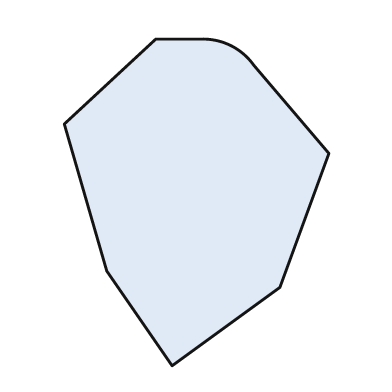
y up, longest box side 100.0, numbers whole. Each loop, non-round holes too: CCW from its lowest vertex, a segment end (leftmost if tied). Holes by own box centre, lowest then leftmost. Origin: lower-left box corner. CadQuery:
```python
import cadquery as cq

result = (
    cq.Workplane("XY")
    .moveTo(33.0, 0.0)
    .lineTo(66.0, 24.0)
    .lineTo(81.0, 65.0)
    .lineTo(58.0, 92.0)
    .threePointArc((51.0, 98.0), (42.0, 100.0))
    .lineTo(28.0, 100.0)
    .lineTo(0.0, 74.0)
    .lineTo(13.0, 29.0)
    .close()
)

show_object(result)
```